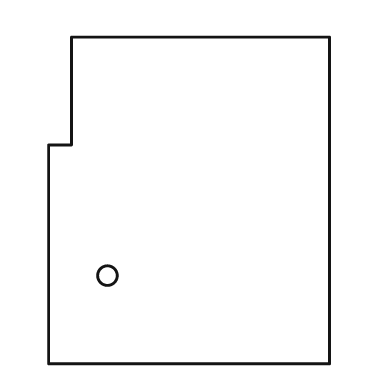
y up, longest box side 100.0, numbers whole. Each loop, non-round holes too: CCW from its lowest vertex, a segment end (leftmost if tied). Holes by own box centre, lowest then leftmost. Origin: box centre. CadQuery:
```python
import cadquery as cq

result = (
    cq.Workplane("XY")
    .moveTo(-43.0, -50.0)
    .lineTo(43.0, -50.0)
    .lineTo(43.0, 50.0)
    .lineTo(-36.0, 50.0)
    .lineTo(-36.0, 17.0)
    .lineTo(-43.0, 17.0)
    .close()
    .moveTo(-25.0, -23.0)
    .circle(3.0)
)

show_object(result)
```